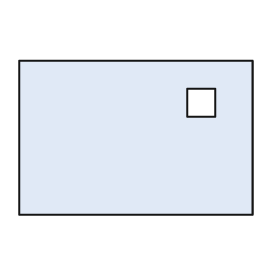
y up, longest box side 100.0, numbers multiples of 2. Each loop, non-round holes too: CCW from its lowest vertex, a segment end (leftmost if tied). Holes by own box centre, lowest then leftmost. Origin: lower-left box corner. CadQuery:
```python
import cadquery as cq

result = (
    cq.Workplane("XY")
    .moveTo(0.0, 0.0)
    .lineTo(100.0, 0.0)
    .lineTo(100.0, 66.0)
    .lineTo(0.0, 66.0)
    .close()
    .moveTo(72.0, 42.0)
    .lineTo(84.0, 42.0)
    .lineTo(84.0, 54.0)
    .lineTo(72.0, 54.0)
    .close()
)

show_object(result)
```